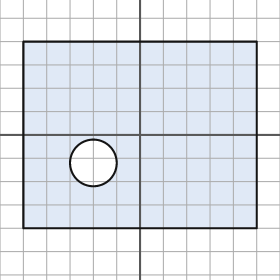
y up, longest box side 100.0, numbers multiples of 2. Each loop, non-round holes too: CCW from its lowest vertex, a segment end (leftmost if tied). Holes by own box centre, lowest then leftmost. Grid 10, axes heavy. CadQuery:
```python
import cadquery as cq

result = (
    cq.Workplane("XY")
    .moveTo(-50.0, -40.0)
    .lineTo(50.0, -40.0)
    .lineTo(50.0, 40.0)
    .lineTo(-50.0, 40.0)
    .close()
    .moveTo(-20.0, -12.0)
    .circle(10.0)
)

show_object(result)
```